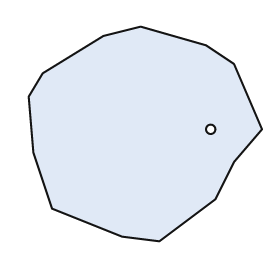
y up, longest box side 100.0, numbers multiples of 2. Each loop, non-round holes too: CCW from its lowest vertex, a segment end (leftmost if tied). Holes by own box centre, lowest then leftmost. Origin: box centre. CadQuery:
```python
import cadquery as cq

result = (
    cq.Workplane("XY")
    .moveTo(6.0, -46.0)
    .lineTo(30.0, -28.0)
    .lineTo(38.0, -12.0)
    .lineTo(50.0, 2.0)
    .lineTo(38.0, 30.0)
    .lineTo(26.0, 38.0)
    .lineTo(-2.0, 46.0)
    .lineTo(-18.0, 42.0)
    .lineTo(-44.0, 26.0)
    .lineTo(-50.0, 16.0)
    .lineTo(-48.0, -8.0)
    .lineTo(-40.0, -32.0)
    .lineTo(-10.0, -44.0)
    .close()
    .moveTo(28.0, 2.0)
    .circle(2.0)
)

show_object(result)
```